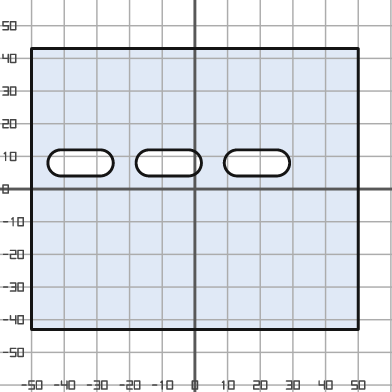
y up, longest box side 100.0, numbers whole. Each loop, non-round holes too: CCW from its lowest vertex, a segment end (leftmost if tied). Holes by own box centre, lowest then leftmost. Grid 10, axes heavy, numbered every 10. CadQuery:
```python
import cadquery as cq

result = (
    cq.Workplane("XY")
    .moveTo(-50.0, -43.0)
    .lineTo(50.0, -43.0)
    .lineTo(50.0, 43.0)
    .lineTo(-50.0, 43.0)
    .close()
    .moveTo(-41.0, 4.0)
    .lineTo(-29.0, 4.0)
    .threePointArc((-25.0, 8.0), (-29.0, 12.0))
    .lineTo(-41.0, 12.0)
    .threePointArc((-45.0, 8.0), (-41.0, 4.0))
    .close()
    .moveTo(-14.0, 4.0)
    .lineTo(-2.0, 4.0)
    .threePointArc((2.0, 8.0), (-2.0, 12.0))
    .lineTo(-14.0, 12.0)
    .threePointArc((-18.0, 8.0), (-14.0, 4.0))
    .close()
    .moveTo(13.0, 4.0)
    .lineTo(25.0, 4.0)
    .threePointArc((29.0, 8.0), (25.0, 12.0))
    .lineTo(13.0, 12.0)
    .threePointArc((9.0, 8.0), (13.0, 4.0))
    .close()
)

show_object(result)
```